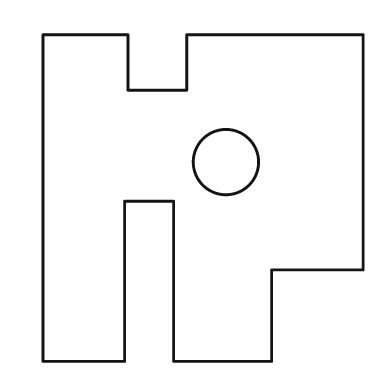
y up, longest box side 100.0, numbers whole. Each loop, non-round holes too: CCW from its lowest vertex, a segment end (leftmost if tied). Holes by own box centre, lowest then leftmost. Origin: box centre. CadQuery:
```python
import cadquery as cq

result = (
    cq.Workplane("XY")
    .moveTo(-49.0, -50.0)
    .lineTo(-24.0, -50.0)
    .lineTo(-24.0, -1.0)
    .lineTo(-9.0, -1.0)
    .lineTo(-9.0, -50.0)
    .lineTo(21.0, -50.0)
    .lineTo(21.0, -22.0)
    .lineTo(49.0, -22.0)
    .lineTo(49.0, 50.0)
    .lineTo(-5.0, 50.0)
    .lineTo(-5.0, 33.0)
    .lineTo(-23.0, 33.0)
    .lineTo(-23.0, 50.0)
    .lineTo(-49.0, 50.0)
    .close()
    .moveTo(7.0, 11.0)
    .circle(10.0)
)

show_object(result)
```